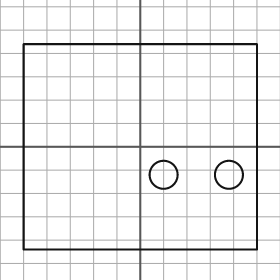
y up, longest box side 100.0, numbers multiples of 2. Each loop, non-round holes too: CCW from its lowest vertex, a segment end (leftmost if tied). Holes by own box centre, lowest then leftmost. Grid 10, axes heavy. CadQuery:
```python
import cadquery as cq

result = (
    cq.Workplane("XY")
    .moveTo(-50.0, -44.0)
    .lineTo(50.0, -44.0)
    .lineTo(50.0, 44.0)
    .lineTo(-50.0, 44.0)
    .close()
    .moveTo(10.0, -12.0)
    .circle(6.0)
    .moveTo(38.0, -12.0)
    .circle(6.0)
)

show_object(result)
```